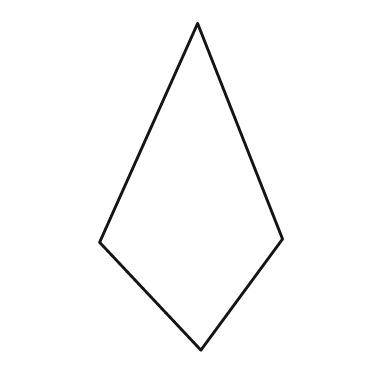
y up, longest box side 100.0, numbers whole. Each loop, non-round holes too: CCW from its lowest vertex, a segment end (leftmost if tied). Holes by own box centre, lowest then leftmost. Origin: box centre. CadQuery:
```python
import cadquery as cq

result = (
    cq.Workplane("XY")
    .moveTo(3.0, -50.0)
    .lineTo(28.0, -16.0)
    .lineTo(2.0, 50.0)
    .lineTo(-28.0, -17.0)
    .close()
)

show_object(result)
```